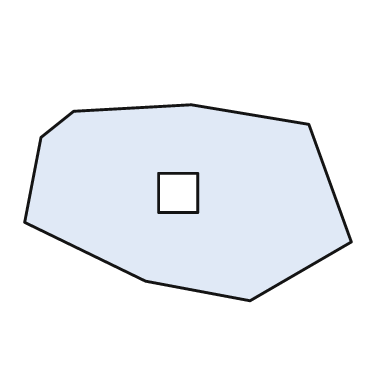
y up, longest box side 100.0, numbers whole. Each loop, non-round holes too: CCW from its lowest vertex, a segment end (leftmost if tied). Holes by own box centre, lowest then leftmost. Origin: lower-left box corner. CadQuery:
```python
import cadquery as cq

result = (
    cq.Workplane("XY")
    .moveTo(69.0, 0.0)
    .lineTo(100.0, 18.0)
    .lineTo(87.0, 54.0)
    .lineTo(51.0, 60.0)
    .lineTo(15.0, 58.0)
    .lineTo(5.0, 50.0)
    .lineTo(0.0, 24.0)
    .lineTo(37.0, 6.0)
    .close()
    .moveTo(41.0, 27.0)
    .lineTo(53.0, 27.0)
    .lineTo(53.0, 39.0)
    .lineTo(41.0, 39.0)
    .close()
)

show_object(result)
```